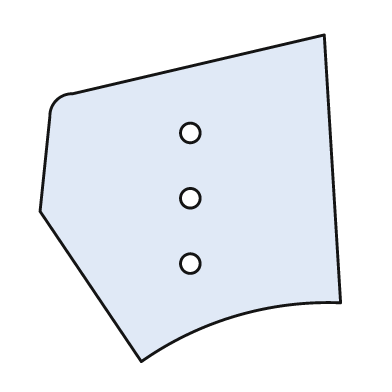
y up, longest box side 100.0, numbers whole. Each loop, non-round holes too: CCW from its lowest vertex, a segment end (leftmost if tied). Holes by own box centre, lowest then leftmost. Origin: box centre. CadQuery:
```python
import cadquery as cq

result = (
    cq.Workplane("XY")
    .moveTo(-15.0, -50.0)
    .threePointArc((14.0, -36.0), (46.0, -32.0))
    .lineTo(41.0, 50.0)
    .lineTo(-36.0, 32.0)
    .threePointArc((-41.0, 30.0), (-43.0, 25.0))
    .lineTo(-46.0, -4.0)
    .close()
    .moveTo(0.0, -20.0)
    .circle(3.0)
    .moveTo(0.0, 0.0)
    .circle(3.0)
    .moveTo(0.0, 20.0)
    .circle(3.0)
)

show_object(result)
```